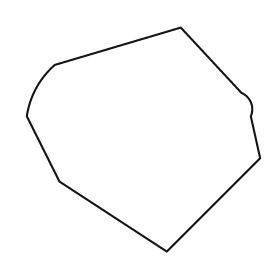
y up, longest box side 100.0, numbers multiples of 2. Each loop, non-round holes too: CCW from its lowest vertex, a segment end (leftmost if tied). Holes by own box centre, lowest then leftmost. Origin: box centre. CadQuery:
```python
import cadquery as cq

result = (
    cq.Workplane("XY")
    .moveTo(10.0, -48.0)
    .lineTo(50.0, -8.0)
    .lineTo(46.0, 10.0)
    .threePointArc((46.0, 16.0), (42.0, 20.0))
    .lineTo(16.0, 48.0)
    .lineTo(-38.0, 32.0)
    .threePointArc((-46.0, 22.0), (-50.0, 10.0))
    .lineTo(-36.0, -18.0)
    .close()
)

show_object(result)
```